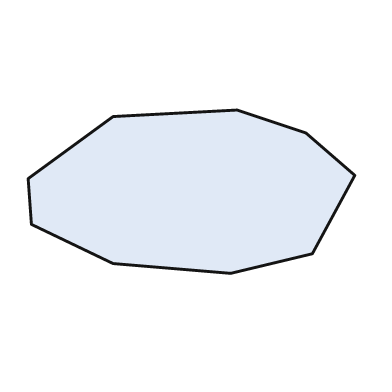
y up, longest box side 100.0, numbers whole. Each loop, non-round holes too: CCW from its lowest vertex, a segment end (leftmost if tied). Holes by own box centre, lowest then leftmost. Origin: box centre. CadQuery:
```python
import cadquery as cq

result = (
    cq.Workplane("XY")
    .moveTo(12.0, -25.0)
    .lineTo(37.0, -19.0)
    .lineTo(50.0, 5.0)
    .lineTo(35.0, 18.0)
    .lineTo(14.0, 25.0)
    .lineTo(-24.0, 23.0)
    .lineTo(-50.0, 4.0)
    .lineTo(-49.0, -10.0)
    .lineTo(-24.0, -22.0)
    .close()
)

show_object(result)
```